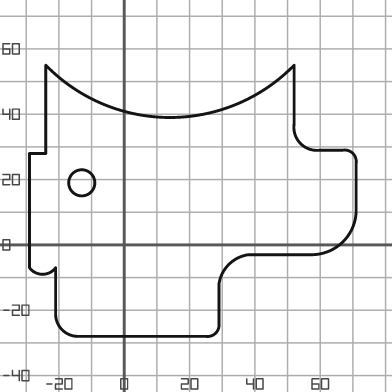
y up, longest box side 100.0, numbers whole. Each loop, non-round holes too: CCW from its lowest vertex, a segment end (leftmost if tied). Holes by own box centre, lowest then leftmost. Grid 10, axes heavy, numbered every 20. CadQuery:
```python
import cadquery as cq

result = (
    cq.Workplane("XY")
    .moveTo(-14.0, -28.0)
    .lineTo(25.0, -28.0)
    .threePointArc((28.0, -27.0), (29.0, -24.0))
    .lineTo(29.0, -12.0)
    .threePointArc((32.0, -6.0), (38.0, -3.0))
    .lineTo(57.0, -3.0)
    .threePointArc((67.0, 1.0), (71.0, 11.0))
    .lineTo(71.0, 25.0)
    .threePointArc((70.0, 28.0), (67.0, 29.0))
    .lineTo(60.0, 29.0)
    .threePointArc((54.0, 31.0), (52.0, 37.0))
    .lineTo(52.0, 55.0)
    .threePointArc((14.0, 39.0), (-24.0, 55.0))
    .lineTo(-24.0, 28.0)
    .lineTo(-29.0, 28.0)
    .lineTo(-29.0, -7.0)
    .threePointArc((-25.0, -9.0), (-21.0, -7.0))
    .lineTo(-21.0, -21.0)
    .threePointArc((-19.0, -26.0), (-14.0, -28.0))
    .close()
    .moveTo(-13.0, 19.0)
    .circle(4.0)
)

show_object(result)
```